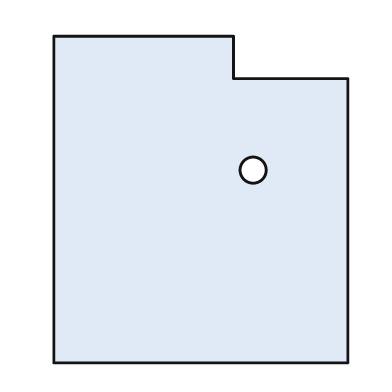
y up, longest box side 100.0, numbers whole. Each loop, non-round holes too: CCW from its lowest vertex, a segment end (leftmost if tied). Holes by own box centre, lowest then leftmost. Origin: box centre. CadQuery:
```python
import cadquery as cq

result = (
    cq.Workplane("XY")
    .moveTo(-45.0, -50.0)
    .lineTo(45.0, -50.0)
    .lineTo(45.0, 37.0)
    .lineTo(10.0, 37.0)
    .lineTo(10.0, 50.0)
    .lineTo(-45.0, 50.0)
    .close()
    .moveTo(16.0, 9.0)
    .circle(4.0)
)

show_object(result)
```